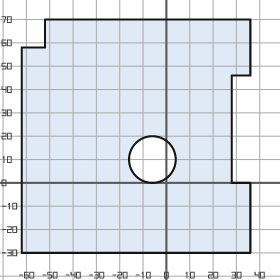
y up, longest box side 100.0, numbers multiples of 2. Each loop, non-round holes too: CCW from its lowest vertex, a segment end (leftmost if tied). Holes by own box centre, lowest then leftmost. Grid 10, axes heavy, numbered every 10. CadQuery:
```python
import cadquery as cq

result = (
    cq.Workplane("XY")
    .moveTo(-62.0, -30.0)
    .lineTo(36.0, -30.0)
    .lineTo(36.0, 0.0)
    .lineTo(28.0, 0.0)
    .lineTo(28.0, 46.0)
    .lineTo(36.0, 46.0)
    .lineTo(36.0, 70.0)
    .lineTo(-52.0, 70.0)
    .lineTo(-52.0, 58.0)
    .lineTo(-62.0, 58.0)
    .close()
    .moveTo(-6.0, 10.0)
    .circle(10.0)
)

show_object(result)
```